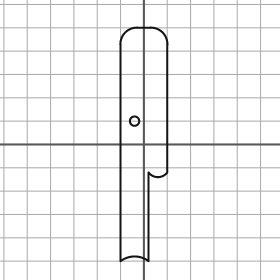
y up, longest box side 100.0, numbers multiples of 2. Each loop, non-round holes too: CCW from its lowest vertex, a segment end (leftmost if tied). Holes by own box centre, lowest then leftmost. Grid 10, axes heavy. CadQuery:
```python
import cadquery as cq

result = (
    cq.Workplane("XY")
    .moveTo(-10.0, -50.0)
    .threePointArc((-4.0, -48.0), (2.0, -50.0))
    .lineTo(2.0, -12.0)
    .threePointArc((6.0, -14.0), (10.0, -12.0))
    .lineTo(10.0, 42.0)
    .threePointArc((8.0, 48.0), (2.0, 50.0))
    .lineTo(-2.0, 50.0)
    .threePointArc((-8.0, 48.0), (-10.0, 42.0))
    .close()
    .moveTo(-4.0, 10.0)
    .circle(2.0)
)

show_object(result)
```